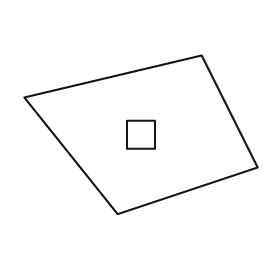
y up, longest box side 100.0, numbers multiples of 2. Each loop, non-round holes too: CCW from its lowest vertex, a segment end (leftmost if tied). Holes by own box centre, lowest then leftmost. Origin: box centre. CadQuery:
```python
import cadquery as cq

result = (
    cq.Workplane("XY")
    .moveTo(-10.0, -34.0)
    .lineTo(50.0, -14.0)
    .lineTo(26.0, 34.0)
    .lineTo(-50.0, 16.0)
    .close()
    .moveTo(-6.0, -6.0)
    .lineTo(6.0, -6.0)
    .lineTo(6.0, 6.0)
    .lineTo(-6.0, 6.0)
    .close()
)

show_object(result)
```